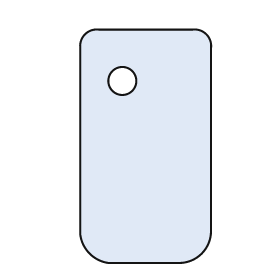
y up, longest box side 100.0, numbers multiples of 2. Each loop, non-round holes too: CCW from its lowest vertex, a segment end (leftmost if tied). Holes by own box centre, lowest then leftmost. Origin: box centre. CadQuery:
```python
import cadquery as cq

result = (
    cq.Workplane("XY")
    .moveTo(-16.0, -50.0)
    .lineTo(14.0, -50.0)
    .threePointArc((24.0, -46.0), (28.0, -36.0))
    .lineTo(28.0, 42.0)
    .threePointArc((26.0, 48.0), (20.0, 50.0))
    .lineTo(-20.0, 50.0)
    .threePointArc((-26.0, 48.0), (-28.0, 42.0))
    .lineTo(-28.0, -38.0)
    .threePointArc((-24.0, -46.0), (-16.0, -50.0))
    .close()
    .moveTo(-10.0, 28.0)
    .circle(6.0)
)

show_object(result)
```